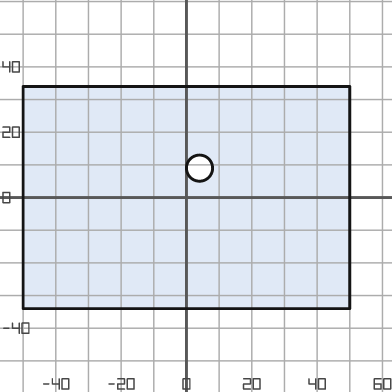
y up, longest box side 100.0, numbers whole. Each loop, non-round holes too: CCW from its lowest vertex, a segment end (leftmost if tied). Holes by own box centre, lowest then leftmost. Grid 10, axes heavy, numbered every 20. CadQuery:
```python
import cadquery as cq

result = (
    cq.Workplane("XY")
    .moveTo(-50.0, -34.0)
    .lineTo(50.0, -34.0)
    .lineTo(50.0, 34.0)
    .lineTo(-50.0, 34.0)
    .close()
    .moveTo(4.0, 9.0)
    .circle(4.0)
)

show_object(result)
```